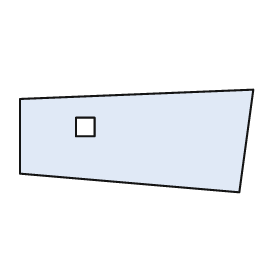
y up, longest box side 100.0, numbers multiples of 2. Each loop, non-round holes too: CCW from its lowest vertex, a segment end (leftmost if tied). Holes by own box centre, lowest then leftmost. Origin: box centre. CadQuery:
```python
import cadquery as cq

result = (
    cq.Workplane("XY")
    .moveTo(44.0, -22.0)
    .lineTo(50.0, 22.0)
    .lineTo(-50.0, 18.0)
    .lineTo(-50.0, -14.0)
    .close()
    .moveTo(-26.0, 2.0)
    .lineTo(-18.0, 2.0)
    .lineTo(-18.0, 10.0)
    .lineTo(-26.0, 10.0)
    .close()
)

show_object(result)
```